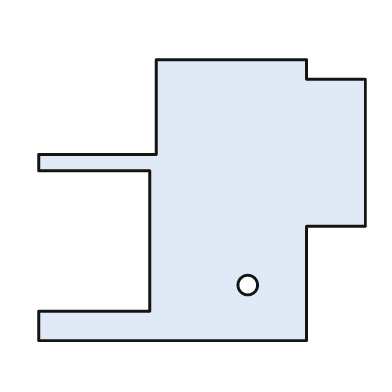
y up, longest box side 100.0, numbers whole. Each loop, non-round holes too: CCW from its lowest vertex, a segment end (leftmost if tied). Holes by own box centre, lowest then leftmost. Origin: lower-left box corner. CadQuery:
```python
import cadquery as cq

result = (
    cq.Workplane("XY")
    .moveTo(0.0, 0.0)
    .lineTo(82.0, 0.0)
    .lineTo(82.0, 35.0)
    .lineTo(100.0, 35.0)
    .lineTo(100.0, 80.0)
    .lineTo(82.0, 80.0)
    .lineTo(82.0, 86.0)
    .lineTo(36.0, 86.0)
    .lineTo(36.0, 57.0)
    .lineTo(0.0, 57.0)
    .lineTo(0.0, 52.0)
    .lineTo(34.0, 52.0)
    .lineTo(34.0, 9.0)
    .lineTo(0.0, 9.0)
    .close()
    .moveTo(64.0, 17.0)
    .circle(3.0)
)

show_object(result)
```